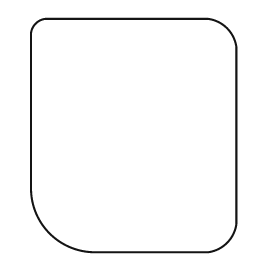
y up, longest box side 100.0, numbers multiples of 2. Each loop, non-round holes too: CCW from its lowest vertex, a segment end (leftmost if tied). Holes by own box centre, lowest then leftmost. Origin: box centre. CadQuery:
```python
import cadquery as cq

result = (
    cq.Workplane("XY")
    .moveTo(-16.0, -50.0)
    .lineTo(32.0, -50.0)
    .threePointArc((40.0, -46.0), (44.0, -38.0))
    .lineTo(44.0, 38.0)
    .threePointArc((40.0, 46.0), (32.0, 50.0))
    .lineTo(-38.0, 50.0)
    .threePointArc((-42.0, 48.0), (-44.0, 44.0))
    .lineTo(-44.0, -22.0)
    .threePointArc((-36.0, -42.0), (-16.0, -50.0))
    .close()
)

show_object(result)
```